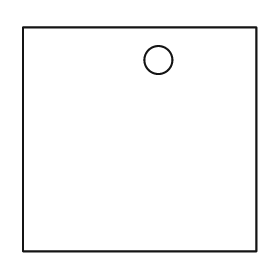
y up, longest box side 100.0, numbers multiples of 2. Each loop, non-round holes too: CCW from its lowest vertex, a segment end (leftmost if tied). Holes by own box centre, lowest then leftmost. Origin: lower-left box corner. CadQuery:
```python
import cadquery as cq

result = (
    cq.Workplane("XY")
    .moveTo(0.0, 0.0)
    .lineTo(100.0, 0.0)
    .lineTo(100.0, 96.0)
    .lineTo(0.0, 96.0)
    .close()
    .moveTo(58.0, 82.0)
    .circle(6.0)
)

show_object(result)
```